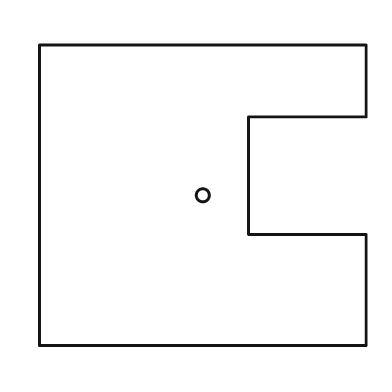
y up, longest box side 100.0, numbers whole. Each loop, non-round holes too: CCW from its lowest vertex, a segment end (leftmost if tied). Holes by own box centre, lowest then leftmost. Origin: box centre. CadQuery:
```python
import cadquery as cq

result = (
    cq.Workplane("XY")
    .moveTo(-50.0, -46.0)
    .lineTo(50.0, -46.0)
    .lineTo(50.0, -12.0)
    .lineTo(14.0, -12.0)
    .lineTo(14.0, 24.0)
    .lineTo(50.0, 24.0)
    .lineTo(50.0, 46.0)
    .lineTo(-50.0, 46.0)
    .close()
    .moveTo(0.0, 0.0)
    .circle(2.0)
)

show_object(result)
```